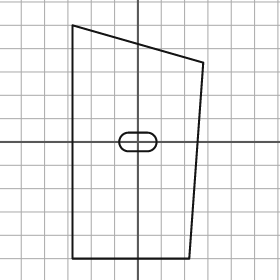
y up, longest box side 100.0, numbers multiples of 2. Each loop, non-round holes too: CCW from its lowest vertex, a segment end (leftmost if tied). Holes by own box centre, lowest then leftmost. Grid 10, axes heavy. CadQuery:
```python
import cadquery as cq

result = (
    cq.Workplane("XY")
    .moveTo(-28.0, -50.0)
    .lineTo(22.0, -50.0)
    .lineTo(28.0, 34.0)
    .lineTo(-28.0, 50.0)
    .close()
    .moveTo(-4.0, -4.0)
    .lineTo(4.0, -4.0)
    .threePointArc((8.0, 0.0), (4.0, 4.0))
    .lineTo(-4.0, 4.0)
    .threePointArc((-8.0, 0.0), (-4.0, -4.0))
    .close()
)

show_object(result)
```